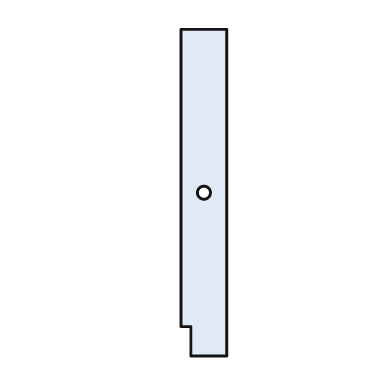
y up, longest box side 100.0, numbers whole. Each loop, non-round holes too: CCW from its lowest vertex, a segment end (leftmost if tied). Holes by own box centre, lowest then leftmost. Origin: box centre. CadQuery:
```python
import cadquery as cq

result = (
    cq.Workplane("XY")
    .moveTo(-4.0, -50.0)
    .lineTo(7.0, -50.0)
    .lineTo(7.0, 50.0)
    .lineTo(-7.0, 50.0)
    .lineTo(-7.0, -41.0)
    .lineTo(-4.0, -41.0)
    .close()
    .moveTo(0.0, 0.0)
    .circle(2.0)
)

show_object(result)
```